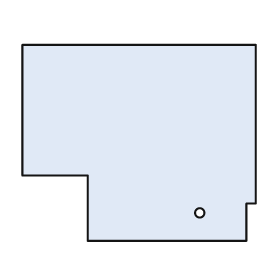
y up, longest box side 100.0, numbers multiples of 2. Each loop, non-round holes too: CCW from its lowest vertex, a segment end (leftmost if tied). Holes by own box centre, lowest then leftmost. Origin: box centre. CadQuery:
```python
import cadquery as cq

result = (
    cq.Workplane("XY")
    .moveTo(-22.0, -42.0)
    .lineTo(46.0, -42.0)
    .lineTo(46.0, -26.0)
    .lineTo(50.0, -26.0)
    .lineTo(50.0, 42.0)
    .lineTo(-50.0, 42.0)
    .lineTo(-50.0, -14.0)
    .lineTo(-22.0, -14.0)
    .close()
    .moveTo(26.0, -30.0)
    .circle(2.0)
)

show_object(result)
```